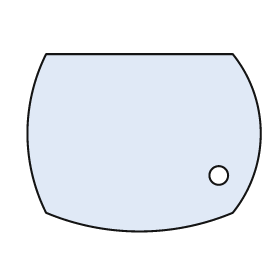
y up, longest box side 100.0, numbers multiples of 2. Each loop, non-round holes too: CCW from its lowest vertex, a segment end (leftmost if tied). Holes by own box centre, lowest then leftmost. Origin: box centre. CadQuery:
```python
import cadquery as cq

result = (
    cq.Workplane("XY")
    .moveTo(-42.0, -30.0)
    .threePointArc((-2.0, -38.0), (38.0, -30.0))
    .threePointArc((50.0, 4.0), (38.0, 38.0))
    .lineTo(-42.0, 38.0)
    .threePointArc((-50.0, 4.0), (-42.0, -30.0))
    .close()
    .moveTo(32.0, -14.0)
    .circle(4.0)
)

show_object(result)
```